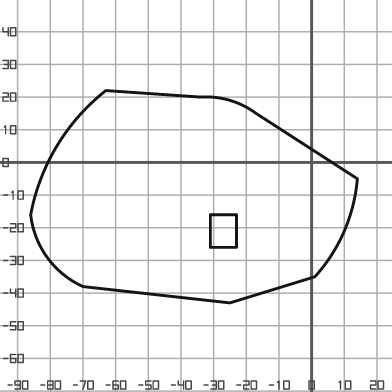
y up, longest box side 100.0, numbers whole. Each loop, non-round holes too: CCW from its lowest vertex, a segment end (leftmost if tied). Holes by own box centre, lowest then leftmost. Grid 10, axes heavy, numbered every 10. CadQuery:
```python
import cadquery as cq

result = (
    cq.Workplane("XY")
    .moveTo(-25.0, -43.0)
    .lineTo(1.0, -35.0)
    .threePointArc((10.0, -21.0), (14.0, -5.0))
    .lineTo(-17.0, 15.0)
    .threePointArc((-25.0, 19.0), (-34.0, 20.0))
    .lineTo(-63.0, 22.0)
    .threePointArc((-78.0, 5.0), (-86.0, -16.0))
    .threePointArc((-81.0, -29.0), (-70.0, -38.0))
    .close()
    .moveTo(-31.0, -26.0)
    .lineTo(-23.0, -26.0)
    .lineTo(-23.0, -16.0)
    .lineTo(-31.0, -16.0)
    .close()
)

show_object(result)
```